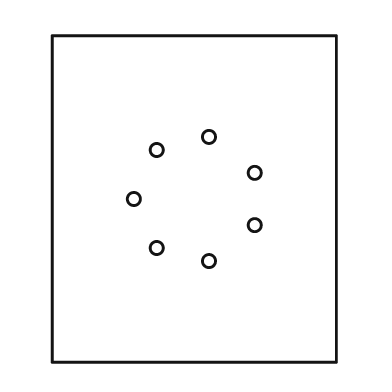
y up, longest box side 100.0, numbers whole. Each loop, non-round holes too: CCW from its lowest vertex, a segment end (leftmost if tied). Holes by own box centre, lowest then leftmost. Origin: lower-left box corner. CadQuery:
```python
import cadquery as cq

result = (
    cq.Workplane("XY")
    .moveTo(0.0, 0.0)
    .lineTo(87.0, 0.0)
    .lineTo(87.0, 100.0)
    .lineTo(0.0, 100.0)
    .close()
    .moveTo(48.0, 31.0)
    .circle(2.0)
    .moveTo(32.0, 35.0)
    .circle(2.0)
    .moveTo(62.0, 42.0)
    .circle(2.0)
    .moveTo(25.0, 50.0)
    .circle(2.0)
    .moveTo(62.0, 58.0)
    .circle(2.0)
    .moveTo(32.0, 65.0)
    .circle(2.0)
    .moveTo(48.0, 69.0)
    .circle(2.0)
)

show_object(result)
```